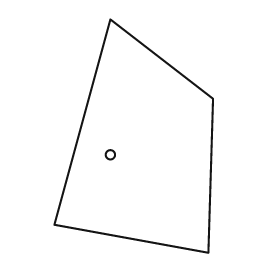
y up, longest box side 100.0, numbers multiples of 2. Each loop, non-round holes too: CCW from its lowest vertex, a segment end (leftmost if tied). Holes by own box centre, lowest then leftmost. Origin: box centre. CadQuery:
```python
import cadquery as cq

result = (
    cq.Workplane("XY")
    .moveTo(32.0, -50.0)
    .lineTo(34.0, 16.0)
    .lineTo(-10.0, 50.0)
    .lineTo(-34.0, -38.0)
    .close()
    .moveTo(-10.0, -8.0)
    .circle(2.0)
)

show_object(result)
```